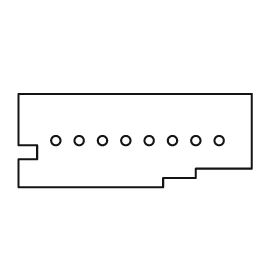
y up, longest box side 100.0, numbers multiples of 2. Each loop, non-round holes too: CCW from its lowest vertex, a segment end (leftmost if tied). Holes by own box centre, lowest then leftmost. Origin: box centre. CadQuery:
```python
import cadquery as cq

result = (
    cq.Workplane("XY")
    .moveTo(-50.0, -20.0)
    .lineTo(12.0, -20.0)
    .lineTo(12.0, -16.0)
    .lineTo(26.0, -16.0)
    .lineTo(26.0, -12.0)
    .lineTo(50.0, -12.0)
    .lineTo(50.0, 20.0)
    .lineTo(-50.0, 20.0)
    .lineTo(-50.0, -2.0)
    .lineTo(-42.0, -2.0)
    .lineTo(-42.0, -8.0)
    .lineTo(-50.0, -8.0)
    .close()
    .moveTo(-34.0, 0.0)
    .circle(2.0)
    .moveTo(-24.0, 0.0)
    .circle(2.0)
    .moveTo(-14.0, 0.0)
    .circle(2.0)
    .moveTo(-4.0, 0.0)
    .circle(2.0)
    .moveTo(6.0, 0.0)
    .circle(2.0)
    .moveTo(16.0, 0.0)
    .circle(2.0)
    .moveTo(26.0, 0.0)
    .circle(2.0)
    .moveTo(36.0, 0.0)
    .circle(2.0)
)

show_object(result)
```